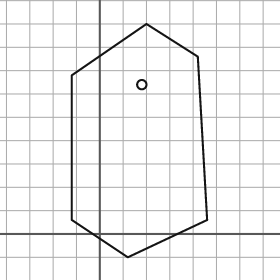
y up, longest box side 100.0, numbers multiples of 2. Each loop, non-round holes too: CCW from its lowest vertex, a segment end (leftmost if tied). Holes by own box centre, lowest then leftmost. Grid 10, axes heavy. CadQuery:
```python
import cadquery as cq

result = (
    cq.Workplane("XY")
    .moveTo(12.0, -10.0)
    .lineTo(46.0, 6.0)
    .lineTo(42.0, 76.0)
    .lineTo(20.0, 90.0)
    .lineTo(-12.0, 68.0)
    .lineTo(-12.0, 6.0)
    .close()
    .moveTo(18.0, 64.0)
    .circle(2.0)
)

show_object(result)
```